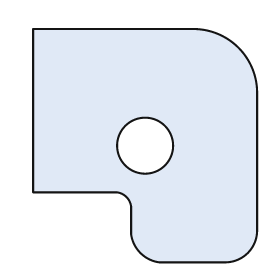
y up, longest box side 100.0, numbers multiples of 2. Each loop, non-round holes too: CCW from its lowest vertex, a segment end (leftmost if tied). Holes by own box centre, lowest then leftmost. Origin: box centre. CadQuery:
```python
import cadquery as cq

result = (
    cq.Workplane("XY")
    .moveTo(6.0, -50.0)
    .lineTo(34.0, -50.0)
    .threePointArc((44.0, -46.0), (48.0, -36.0))
    .lineTo(48.0, 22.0)
    .threePointArc((40.0, 42.0), (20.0, 50.0))
    .lineTo(-48.0, 50.0)
    .lineTo(-48.0, -20.0)
    .lineTo(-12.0, -20.0)
    .threePointArc((-8.0, -22.0), (-6.0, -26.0))
    .lineTo(-6.0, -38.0)
    .threePointArc((-2.0, -46.0), (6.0, -50.0))
    .close()
    .moveTo(0.0, 0.0)
    .circle(12.0)
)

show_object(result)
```